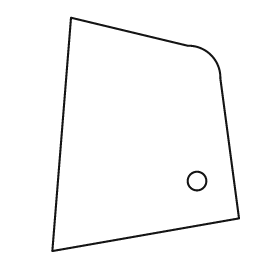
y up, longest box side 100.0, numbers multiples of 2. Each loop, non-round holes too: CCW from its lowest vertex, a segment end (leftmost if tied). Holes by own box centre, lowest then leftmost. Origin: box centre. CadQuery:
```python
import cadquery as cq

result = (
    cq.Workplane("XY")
    .moveTo(-40.0, -50.0)
    .lineTo(40.0, -36.0)
    .lineTo(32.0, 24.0)
    .threePointArc((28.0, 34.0), (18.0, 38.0))
    .lineTo(-32.0, 50.0)
    .close()
    .moveTo(22.0, -20.0)
    .circle(4.0)
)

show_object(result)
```